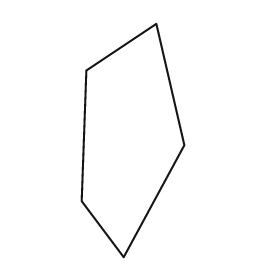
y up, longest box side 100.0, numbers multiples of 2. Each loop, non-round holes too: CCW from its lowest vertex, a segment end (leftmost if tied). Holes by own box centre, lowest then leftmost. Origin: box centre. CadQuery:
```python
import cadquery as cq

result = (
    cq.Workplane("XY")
    .moveTo(-4.0, -50.0)
    .lineTo(22.0, -2.0)
    .lineTo(10.0, 50.0)
    .lineTo(-20.0, 30.0)
    .lineTo(-22.0, -26.0)
    .close()
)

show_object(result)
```